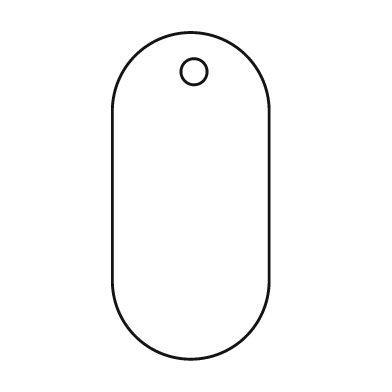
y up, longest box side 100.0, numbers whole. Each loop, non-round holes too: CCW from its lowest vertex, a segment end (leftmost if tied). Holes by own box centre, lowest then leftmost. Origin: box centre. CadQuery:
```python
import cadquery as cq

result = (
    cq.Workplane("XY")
    .moveTo(-24.0, -26.0)
    .threePointArc((0.0, -50.0), (24.0, -26.0))
    .lineTo(24.0, 26.0)
    .threePointArc((0.0, 50.0), (-24.0, 26.0))
    .close()
    .moveTo(1.0, 38.0)
    .circle(4.0)
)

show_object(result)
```